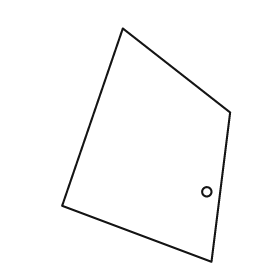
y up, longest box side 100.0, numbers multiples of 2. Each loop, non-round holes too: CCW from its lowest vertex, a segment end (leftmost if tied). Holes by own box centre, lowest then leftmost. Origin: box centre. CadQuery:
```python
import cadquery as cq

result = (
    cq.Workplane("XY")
    .moveTo(28.0, -50.0)
    .lineTo(36.0, 14.0)
    .lineTo(-10.0, 50.0)
    .lineTo(-36.0, -26.0)
    .close()
    .moveTo(26.0, -20.0)
    .circle(2.0)
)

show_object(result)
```